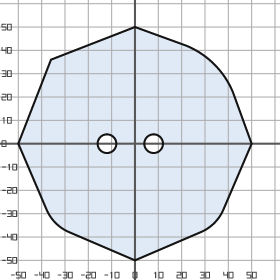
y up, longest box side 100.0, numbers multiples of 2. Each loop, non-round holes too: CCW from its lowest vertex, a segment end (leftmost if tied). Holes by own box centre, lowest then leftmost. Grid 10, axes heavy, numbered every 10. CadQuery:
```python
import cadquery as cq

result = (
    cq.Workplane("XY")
    .moveTo(0.0, -50.0)
    .lineTo(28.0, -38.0)
    .threePointArc((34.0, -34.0), (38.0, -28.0))
    .lineTo(50.0, 0.0)
    .lineTo(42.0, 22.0)
    .threePointArc((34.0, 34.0), (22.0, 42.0))
    .lineTo(0.0, 50.0)
    .lineTo(-36.0, 36.0)
    .lineTo(-50.0, 0.0)
    .lineTo(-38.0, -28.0)
    .threePointArc((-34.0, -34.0), (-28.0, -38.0))
    .close()
    .moveTo(-12.0, 0.0)
    .circle(4.0)
    .moveTo(8.0, 0.0)
    .circle(4.0)
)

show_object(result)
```